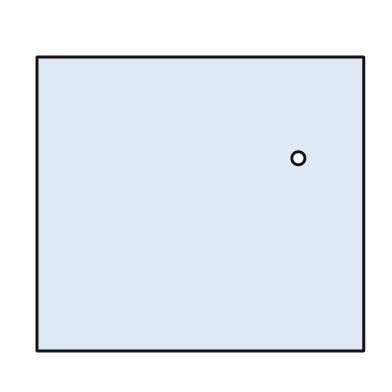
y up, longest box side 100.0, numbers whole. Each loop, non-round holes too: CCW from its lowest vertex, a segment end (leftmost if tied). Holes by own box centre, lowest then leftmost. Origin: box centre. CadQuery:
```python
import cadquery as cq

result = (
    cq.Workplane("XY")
    .moveTo(-50.0, -45.0)
    .lineTo(50.0, -45.0)
    .lineTo(50.0, 45.0)
    .lineTo(-50.0, 45.0)
    .close()
    .moveTo(30.0, 14.0)
    .circle(2.0)
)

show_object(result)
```